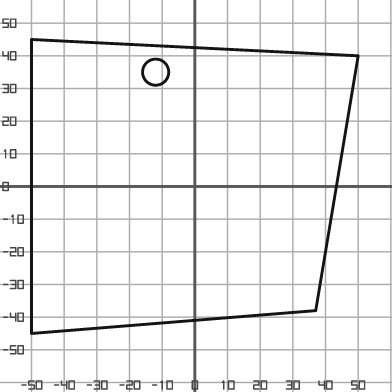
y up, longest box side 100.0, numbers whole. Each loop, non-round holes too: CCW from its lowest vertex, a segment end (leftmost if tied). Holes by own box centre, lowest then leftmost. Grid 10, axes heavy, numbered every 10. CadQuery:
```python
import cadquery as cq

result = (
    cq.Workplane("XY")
    .moveTo(-50.0, -45.0)
    .lineTo(37.0, -38.0)
    .lineTo(50.0, 40.0)
    .lineTo(-50.0, 45.0)
    .close()
    .moveTo(-12.0, 35.0)
    .circle(4.0)
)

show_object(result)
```